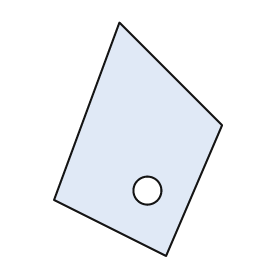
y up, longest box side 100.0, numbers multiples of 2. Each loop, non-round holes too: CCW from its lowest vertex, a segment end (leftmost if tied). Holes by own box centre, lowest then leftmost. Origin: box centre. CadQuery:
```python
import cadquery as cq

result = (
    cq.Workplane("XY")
    .moveTo(12.0, -50.0)
    .lineTo(36.0, 6.0)
    .lineTo(-8.0, 50.0)
    .lineTo(-36.0, -26.0)
    .close()
    .moveTo(4.0, -22.0)
    .circle(6.0)
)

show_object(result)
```